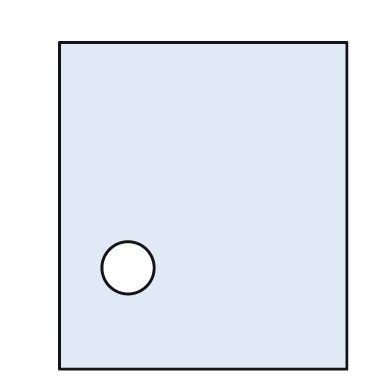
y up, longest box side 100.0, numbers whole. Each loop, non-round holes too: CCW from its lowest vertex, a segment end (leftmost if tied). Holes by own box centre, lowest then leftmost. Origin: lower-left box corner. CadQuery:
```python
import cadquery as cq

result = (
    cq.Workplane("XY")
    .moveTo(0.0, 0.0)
    .lineTo(88.0, 0.0)
    .lineTo(88.0, 100.0)
    .lineTo(0.0, 100.0)
    .close()
    .moveTo(21.0, 31.0)
    .circle(8.0)
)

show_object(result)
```